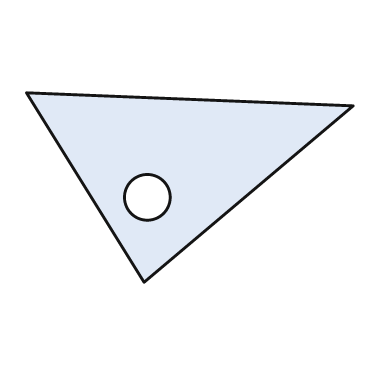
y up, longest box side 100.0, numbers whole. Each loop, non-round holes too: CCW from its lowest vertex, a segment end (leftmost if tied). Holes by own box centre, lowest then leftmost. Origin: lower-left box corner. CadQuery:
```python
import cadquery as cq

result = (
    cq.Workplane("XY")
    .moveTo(36.0, 0.0)
    .lineTo(100.0, 54.0)
    .lineTo(0.0, 58.0)
    .close()
    .moveTo(37.0, 26.0)
    .circle(7.0)
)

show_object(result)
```